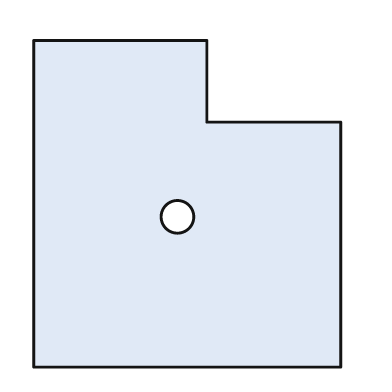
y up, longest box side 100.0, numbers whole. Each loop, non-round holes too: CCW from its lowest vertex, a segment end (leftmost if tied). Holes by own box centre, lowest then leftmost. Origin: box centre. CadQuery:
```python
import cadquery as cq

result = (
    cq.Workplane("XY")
    .moveTo(-47.0, -50.0)
    .lineTo(47.0, -50.0)
    .lineTo(47.0, 25.0)
    .lineTo(6.0, 25.0)
    .lineTo(6.0, 50.0)
    .lineTo(-47.0, 50.0)
    .close()
    .moveTo(-3.0, -4.0)
    .circle(5.0)
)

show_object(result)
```